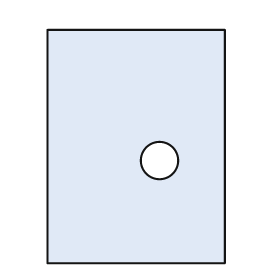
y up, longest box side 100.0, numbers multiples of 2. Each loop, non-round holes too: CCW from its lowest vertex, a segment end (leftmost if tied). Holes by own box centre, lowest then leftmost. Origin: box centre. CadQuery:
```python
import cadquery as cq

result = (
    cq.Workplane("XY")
    .moveTo(-38.0, -50.0)
    .lineTo(38.0, -50.0)
    .lineTo(38.0, 50.0)
    .lineTo(-38.0, 50.0)
    .close()
    .moveTo(10.0, -6.0)
    .circle(8.0)
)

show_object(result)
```